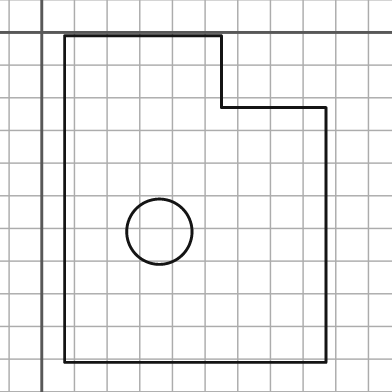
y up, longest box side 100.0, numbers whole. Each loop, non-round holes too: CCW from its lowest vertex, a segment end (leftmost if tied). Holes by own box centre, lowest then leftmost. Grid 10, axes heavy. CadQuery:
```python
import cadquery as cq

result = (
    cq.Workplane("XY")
    .moveTo(7.0, -101.0)
    .lineTo(87.0, -101.0)
    .lineTo(87.0, -23.0)
    .lineTo(55.0, -23.0)
    .lineTo(55.0, -1.0)
    .lineTo(7.0, -1.0)
    .close()
    .moveTo(36.0, -61.0)
    .circle(10.0)
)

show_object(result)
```